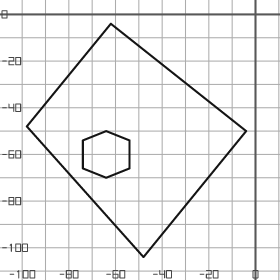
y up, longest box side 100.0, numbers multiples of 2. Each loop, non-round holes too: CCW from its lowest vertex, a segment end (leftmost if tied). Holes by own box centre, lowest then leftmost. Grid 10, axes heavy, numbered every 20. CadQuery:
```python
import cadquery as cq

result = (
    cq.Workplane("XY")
    .moveTo(-48.0, -104.0)
    .lineTo(-4.0, -50.0)
    .lineTo(-62.0, -4.0)
    .lineTo(-98.0, -48.0)
    .close()
    .moveTo(-64.0, -70.0)
    .lineTo(-54.0, -66.0)
    .lineTo(-54.0, -54.0)
    .lineTo(-64.0, -50.0)
    .lineTo(-74.0, -54.0)
    .lineTo(-74.0, -66.0)
    .close()
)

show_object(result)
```